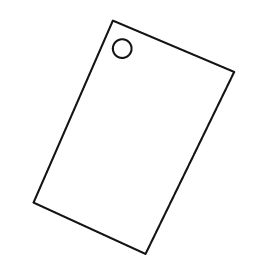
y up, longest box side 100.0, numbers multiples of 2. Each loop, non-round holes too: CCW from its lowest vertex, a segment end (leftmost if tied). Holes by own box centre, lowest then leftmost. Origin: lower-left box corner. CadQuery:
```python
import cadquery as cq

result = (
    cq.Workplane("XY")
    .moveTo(48.0, 0.0)
    .lineTo(86.0, 78.0)
    .lineTo(34.0, 100.0)
    .lineTo(0.0, 22.0)
    .close()
    .moveTo(38.0, 88.0)
    .circle(4.0)
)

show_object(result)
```